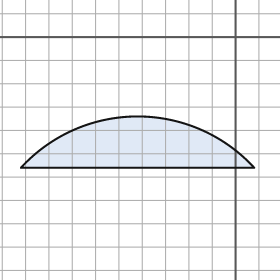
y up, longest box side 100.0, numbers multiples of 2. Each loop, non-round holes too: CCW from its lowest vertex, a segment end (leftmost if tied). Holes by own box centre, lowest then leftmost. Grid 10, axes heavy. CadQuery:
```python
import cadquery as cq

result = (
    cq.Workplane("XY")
    .moveTo(-92.0, -56.0)
    .lineTo(8.0, -56.0)
    .threePointArc((-42.0, -34.0), (-92.0, -56.0))
    .close()
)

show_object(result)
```